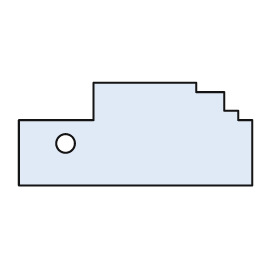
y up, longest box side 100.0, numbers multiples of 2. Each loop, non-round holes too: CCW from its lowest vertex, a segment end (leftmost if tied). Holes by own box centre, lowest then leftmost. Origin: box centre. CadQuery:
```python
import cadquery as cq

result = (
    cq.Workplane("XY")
    .moveTo(-50.0, -22.0)
    .lineTo(50.0, -22.0)
    .lineTo(50.0, 6.0)
    .lineTo(44.0, 6.0)
    .lineTo(44.0, 10.0)
    .lineTo(38.0, 10.0)
    .lineTo(38.0, 18.0)
    .lineTo(26.0, 18.0)
    .lineTo(26.0, 22.0)
    .lineTo(-18.0, 22.0)
    .lineTo(-18.0, 6.0)
    .lineTo(-50.0, 6.0)
    .close()
    .moveTo(-30.0, -4.0)
    .circle(4.0)
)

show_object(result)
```